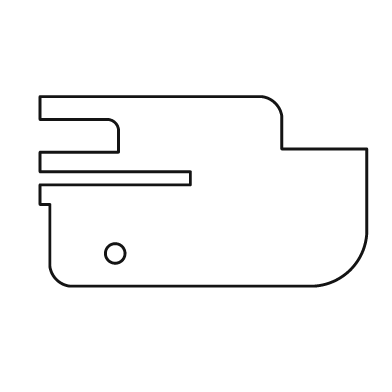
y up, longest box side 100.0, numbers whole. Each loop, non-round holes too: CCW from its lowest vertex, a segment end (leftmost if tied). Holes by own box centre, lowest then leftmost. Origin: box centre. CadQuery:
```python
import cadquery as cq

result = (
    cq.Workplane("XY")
    .moveTo(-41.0, -29.0)
    .lineTo(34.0, -29.0)
    .threePointArc((45.0, -24.0), (50.0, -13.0))
    .lineTo(50.0, 13.0)
    .lineTo(24.0, 13.0)
    .lineTo(24.0, 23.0)
    .threePointArc((22.0, 27.0), (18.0, 29.0))
    .lineTo(-50.0, 29.0)
    .lineTo(-50.0, 22.0)
    .lineTo(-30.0, 22.0)
    .threePointArc((-27.0, 21.0), (-26.0, 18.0))
    .lineTo(-26.0, 12.0)
    .lineTo(-50.0, 12.0)
    .lineTo(-50.0, 6.0)
    .lineTo(-4.0, 6.0)
    .lineTo(-4.0, 2.0)
    .lineTo(-50.0, 2.0)
    .lineTo(-50.0, -4.0)
    .lineTo(-47.0, -4.0)
    .lineTo(-47.0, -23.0)
    .threePointArc((-45.0, -27.0), (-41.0, -29.0))
    .close()
    .moveTo(-27.0, -19.0)
    .circle(3.0)
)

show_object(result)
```